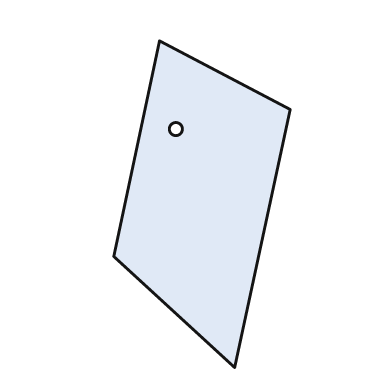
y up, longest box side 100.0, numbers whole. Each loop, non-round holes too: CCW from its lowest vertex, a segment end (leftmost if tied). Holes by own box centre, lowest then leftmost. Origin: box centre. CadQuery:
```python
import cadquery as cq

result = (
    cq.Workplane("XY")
    .moveTo(10.0, -50.0)
    .lineTo(27.0, 29.0)
    .lineTo(-13.0, 50.0)
    .lineTo(-27.0, -16.0)
    .close()
    .moveTo(-8.0, 23.0)
    .circle(2.0)
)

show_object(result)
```